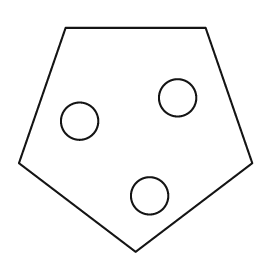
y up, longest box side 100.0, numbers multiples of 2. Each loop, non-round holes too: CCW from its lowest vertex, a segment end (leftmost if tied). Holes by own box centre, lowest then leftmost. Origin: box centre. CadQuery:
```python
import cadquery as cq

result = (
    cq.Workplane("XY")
    .moveTo(0.0, -48.0)
    .lineTo(50.0, -10.0)
    .lineTo(30.0, 48.0)
    .lineTo(-30.0, 48.0)
    .lineTo(-50.0, -10.0)
    .close()
    .moveTo(6.0, -24.0)
    .circle(8.0)
    .moveTo(-24.0, 8.0)
    .circle(8.0)
    .moveTo(18.0, 18.0)
    .circle(8.0)
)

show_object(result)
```